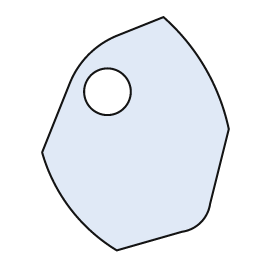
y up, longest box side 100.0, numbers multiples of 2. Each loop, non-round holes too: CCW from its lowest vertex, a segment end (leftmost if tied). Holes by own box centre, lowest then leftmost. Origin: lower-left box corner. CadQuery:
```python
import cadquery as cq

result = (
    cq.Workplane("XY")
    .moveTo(32.0, 0.0)
    .lineTo(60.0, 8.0)
    .threePointArc((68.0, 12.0), (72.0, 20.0))
    .lineTo(80.0, 52.0)
    .threePointArc((70.0, 78.0), (52.0, 100.0))
    .lineTo(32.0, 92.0)
    .threePointArc((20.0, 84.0), (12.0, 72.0))
    .lineTo(0.0, 42.0)
    .threePointArc((12.0, 18.0), (32.0, 0.0))
    .close()
    .moveTo(28.0, 68.0)
    .circle(10.0)
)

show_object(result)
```